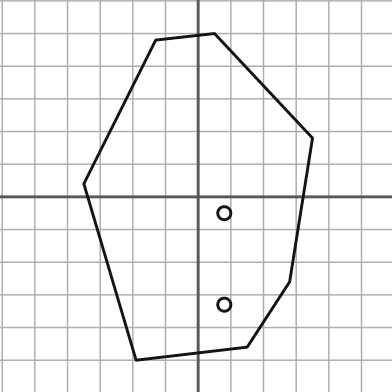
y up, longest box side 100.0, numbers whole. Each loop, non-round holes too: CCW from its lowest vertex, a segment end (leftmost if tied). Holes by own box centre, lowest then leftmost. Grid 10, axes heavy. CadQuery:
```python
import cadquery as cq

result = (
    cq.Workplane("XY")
    .moveTo(-19.0, -50.0)
    .lineTo(15.0, -46.0)
    .lineTo(28.0, -26.0)
    .lineTo(35.0, 18.0)
    .lineTo(5.0, 50.0)
    .lineTo(-13.0, 48.0)
    .lineTo(-35.0, 4.0)
    .close()
    .moveTo(8.0, -33.0)
    .circle(2.0)
    .moveTo(8.0, -5.0)
    .circle(2.0)
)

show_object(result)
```